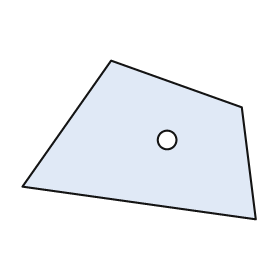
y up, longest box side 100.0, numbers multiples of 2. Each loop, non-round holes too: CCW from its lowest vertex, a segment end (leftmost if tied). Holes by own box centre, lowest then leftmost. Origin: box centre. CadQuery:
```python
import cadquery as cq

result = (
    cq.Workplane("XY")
    .moveTo(50.0, -34.0)
    .lineTo(44.0, 14.0)
    .lineTo(-12.0, 34.0)
    .lineTo(-50.0, -20.0)
    .close()
    .moveTo(12.0, 0.0)
    .circle(4.0)
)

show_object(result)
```